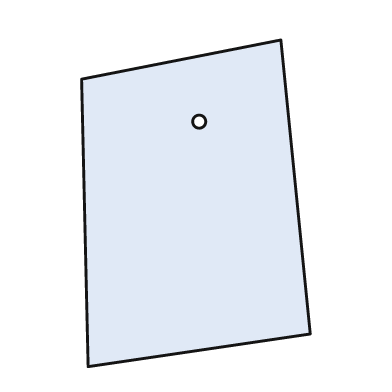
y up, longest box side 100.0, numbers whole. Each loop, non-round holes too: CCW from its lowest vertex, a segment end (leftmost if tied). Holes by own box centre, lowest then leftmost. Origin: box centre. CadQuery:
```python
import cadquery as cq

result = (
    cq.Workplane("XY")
    .moveTo(-33.0, -50.0)
    .lineTo(35.0, -40.0)
    .lineTo(26.0, 50.0)
    .lineTo(-35.0, 38.0)
    .close()
    .moveTo(1.0, 25.0)
    .circle(2.0)
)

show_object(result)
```